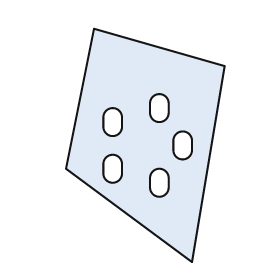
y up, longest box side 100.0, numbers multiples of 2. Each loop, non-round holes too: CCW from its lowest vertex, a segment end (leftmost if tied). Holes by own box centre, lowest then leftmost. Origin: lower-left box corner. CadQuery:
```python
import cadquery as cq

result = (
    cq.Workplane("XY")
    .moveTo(54.0, 0.0)
    .lineTo(68.0, 84.0)
    .lineTo(12.0, 100.0)
    .lineTo(0.0, 40.0)
    .close()
    .moveTo(36.0, 32.0)
    .threePointArc((40.0, 28.0), (44.0, 32.0))
    .lineTo(44.0, 36.0)
    .threePointArc((40.0, 40.0), (36.0, 36.0))
    .close()
    .moveTo(16.0, 38.0)
    .threePointArc((20.0, 34.0), (24.0, 38.0))
    .lineTo(24.0, 42.0)
    .threePointArc((20.0, 46.0), (16.0, 42.0))
    .close()
    .moveTo(46.0, 48.0)
    .threePointArc((50.0, 44.0), (54.0, 48.0))
    .lineTo(54.0, 52.0)
    .threePointArc((50.0, 56.0), (46.0, 52.0))
    .close()
    .moveTo(16.0, 58.0)
    .threePointArc((20.0, 54.0), (24.0, 58.0))
    .lineTo(24.0, 62.0)
    .threePointArc((20.0, 66.0), (16.0, 62.0))
    .close()
    .moveTo(36.0, 64.0)
    .threePointArc((40.0, 60.0), (44.0, 64.0))
    .lineTo(44.0, 68.0)
    .threePointArc((40.0, 72.0), (36.0, 68.0))
    .close()
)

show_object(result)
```